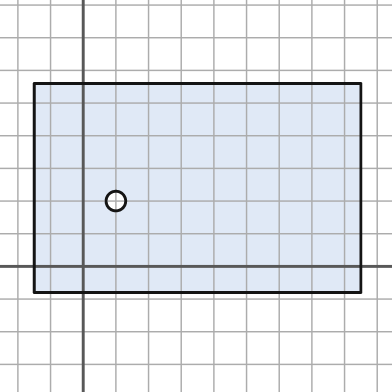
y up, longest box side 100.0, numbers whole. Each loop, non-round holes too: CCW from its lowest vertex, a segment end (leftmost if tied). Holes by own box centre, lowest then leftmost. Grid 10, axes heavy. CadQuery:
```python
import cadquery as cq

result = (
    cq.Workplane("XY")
    .moveTo(-15.0, -8.0)
    .lineTo(85.0, -8.0)
    .lineTo(85.0, 56.0)
    .lineTo(-15.0, 56.0)
    .close()
    .moveTo(10.0, 20.0)
    .circle(3.0)
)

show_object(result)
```